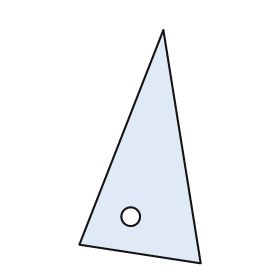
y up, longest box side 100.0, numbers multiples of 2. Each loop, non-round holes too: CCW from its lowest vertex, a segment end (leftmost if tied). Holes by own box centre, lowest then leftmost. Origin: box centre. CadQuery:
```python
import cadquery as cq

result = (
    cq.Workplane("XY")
    .moveTo(26.0, -50.0)
    .lineTo(10.0, 50.0)
    .lineTo(-26.0, -42.0)
    .close()
    .moveTo(-4.0, -30.0)
    .circle(4.0)
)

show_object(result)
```